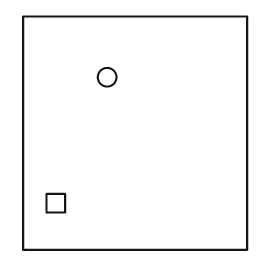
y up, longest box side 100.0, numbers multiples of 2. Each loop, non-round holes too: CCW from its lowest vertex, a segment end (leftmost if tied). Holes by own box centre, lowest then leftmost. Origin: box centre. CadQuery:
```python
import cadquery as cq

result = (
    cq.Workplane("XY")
    .moveTo(-48.0, -50.0)
    .lineTo(48.0, -50.0)
    .lineTo(48.0, 50.0)
    .lineTo(-48.0, 50.0)
    .close()
    .moveTo(-38.0, -34.0)
    .lineTo(-30.0, -34.0)
    .lineTo(-30.0, -26.0)
    .lineTo(-38.0, -26.0)
    .close()
    .moveTo(-12.0, 24.0)
    .circle(4.0)
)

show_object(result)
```